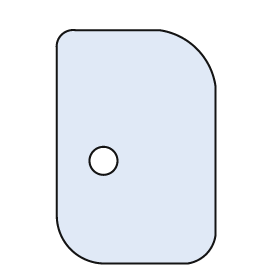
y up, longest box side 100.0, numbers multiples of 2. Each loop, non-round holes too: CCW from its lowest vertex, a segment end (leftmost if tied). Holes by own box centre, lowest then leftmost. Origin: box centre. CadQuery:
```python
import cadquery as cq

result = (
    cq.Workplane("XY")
    .moveTo(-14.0, -50.0)
    .lineTo(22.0, -50.0)
    .threePointArc((30.0, -46.0), (34.0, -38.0))
    .lineTo(34.0, 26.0)
    .threePointArc((26.0, 42.0), (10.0, 50.0))
    .lineTo(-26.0, 50.0)
    .threePointArc((-32.0, 48.0), (-34.0, 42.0))
    .lineTo(-34.0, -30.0)
    .threePointArc((-28.0, -44.0), (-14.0, -50.0))
    .close()
    .moveTo(-14.0, -6.0)
    .circle(6.0)
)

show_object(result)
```